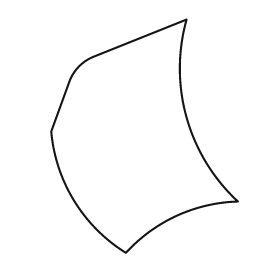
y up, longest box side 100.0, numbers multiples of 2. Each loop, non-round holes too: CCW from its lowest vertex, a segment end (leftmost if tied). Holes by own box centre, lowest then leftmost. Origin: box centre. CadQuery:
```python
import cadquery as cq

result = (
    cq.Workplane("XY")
    .moveTo(-8.0, -50.0)
    .threePointArc((14.0, -34.0), (40.0, -28.0))
    .threePointArc((18.0, 8.0), (18.0, 50.0))
    .lineTo(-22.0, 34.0)
    .threePointArc((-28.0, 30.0), (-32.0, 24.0))
    .lineTo(-40.0, 2.0)
    .threePointArc((-30.0, -28.0), (-8.0, -50.0))
    .close()
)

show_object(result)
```